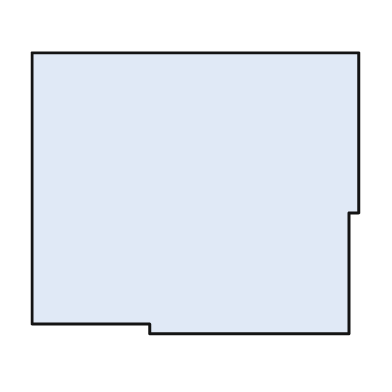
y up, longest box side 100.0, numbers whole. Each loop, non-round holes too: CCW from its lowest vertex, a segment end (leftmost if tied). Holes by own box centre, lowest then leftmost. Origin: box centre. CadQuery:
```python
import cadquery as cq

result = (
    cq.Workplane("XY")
    .moveTo(-14.0, -43.0)
    .lineTo(47.0, -43.0)
    .lineTo(47.0, -6.0)
    .lineTo(50.0, -6.0)
    .lineTo(50.0, 43.0)
    .lineTo(-50.0, 43.0)
    .lineTo(-50.0, -40.0)
    .lineTo(-14.0, -40.0)
    .close()
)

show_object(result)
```